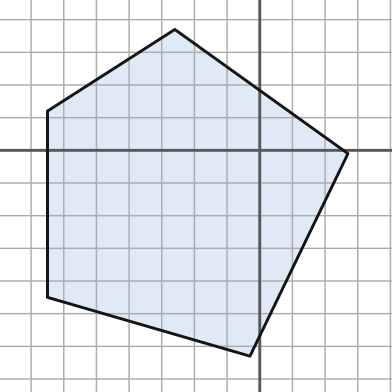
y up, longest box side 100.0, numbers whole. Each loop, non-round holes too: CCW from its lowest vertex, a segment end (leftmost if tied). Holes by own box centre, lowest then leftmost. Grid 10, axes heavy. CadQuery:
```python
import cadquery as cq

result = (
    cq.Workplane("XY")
    .moveTo(-3.0, -63.0)
    .lineTo(27.0, -1.0)
    .lineTo(-26.0, 37.0)
    .lineTo(-65.0, 12.0)
    .lineTo(-65.0, -45.0)
    .close()
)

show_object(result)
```